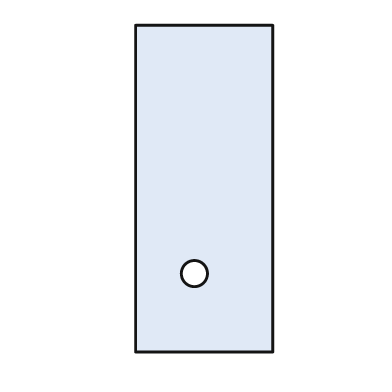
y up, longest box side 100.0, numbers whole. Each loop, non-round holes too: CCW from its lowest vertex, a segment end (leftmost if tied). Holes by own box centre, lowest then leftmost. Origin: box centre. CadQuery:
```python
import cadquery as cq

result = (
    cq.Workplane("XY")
    .moveTo(-21.0, -50.0)
    .lineTo(21.0, -50.0)
    .lineTo(21.0, 50.0)
    .lineTo(-21.0, 50.0)
    .close()
    .moveTo(-3.0, -26.0)
    .circle(4.0)
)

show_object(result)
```